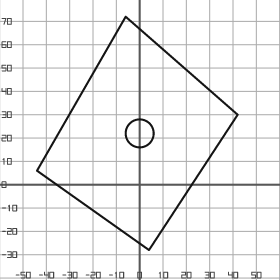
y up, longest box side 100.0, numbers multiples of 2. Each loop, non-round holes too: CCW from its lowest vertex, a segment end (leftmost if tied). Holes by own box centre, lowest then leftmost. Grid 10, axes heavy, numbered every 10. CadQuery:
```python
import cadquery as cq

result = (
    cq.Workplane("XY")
    .moveTo(4.0, -28.0)
    .lineTo(42.0, 30.0)
    .lineTo(-6.0, 72.0)
    .lineTo(-44.0, 6.0)
    .close()
    .moveTo(0.0, 22.0)
    .circle(6.0)
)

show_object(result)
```